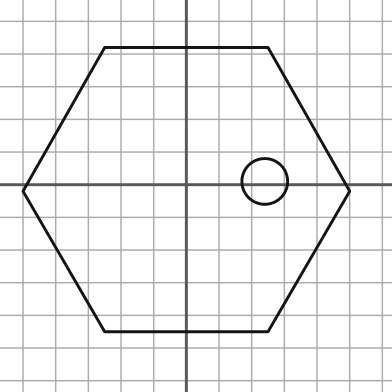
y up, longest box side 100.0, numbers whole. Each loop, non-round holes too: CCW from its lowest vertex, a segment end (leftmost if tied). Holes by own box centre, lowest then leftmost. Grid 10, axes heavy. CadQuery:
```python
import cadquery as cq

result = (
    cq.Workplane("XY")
    .moveTo(-25.0, -45.0)
    .lineTo(25.0, -45.0)
    .lineTo(50.0, -2.0)
    .lineTo(25.0, 42.0)
    .lineTo(-25.0, 42.0)
    .lineTo(-50.0, -2.0)
    .close()
    .moveTo(24.0, 1.0)
    .circle(7.0)
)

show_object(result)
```